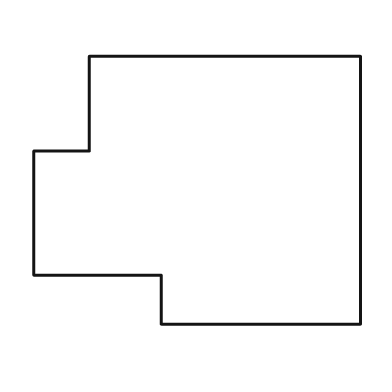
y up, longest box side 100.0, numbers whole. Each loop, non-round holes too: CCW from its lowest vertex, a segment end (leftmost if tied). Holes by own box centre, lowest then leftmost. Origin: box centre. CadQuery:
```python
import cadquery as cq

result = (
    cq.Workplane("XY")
    .moveTo(-11.0, -41.0)
    .lineTo(50.0, -41.0)
    .lineTo(50.0, 41.0)
    .lineTo(-33.0, 41.0)
    .lineTo(-33.0, 12.0)
    .lineTo(-50.0, 12.0)
    .lineTo(-50.0, -26.0)
    .lineTo(-11.0, -26.0)
    .close()
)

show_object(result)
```